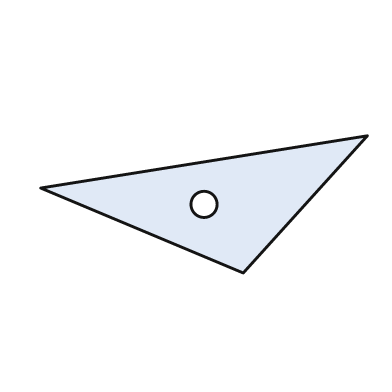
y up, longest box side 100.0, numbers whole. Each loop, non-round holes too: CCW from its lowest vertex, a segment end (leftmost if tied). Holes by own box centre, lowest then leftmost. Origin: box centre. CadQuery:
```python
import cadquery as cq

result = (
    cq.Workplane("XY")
    .moveTo(12.0, -21.0)
    .lineTo(50.0, 21.0)
    .lineTo(-50.0, 5.0)
    .close()
    .moveTo(0.0, 0.0)
    .circle(4.0)
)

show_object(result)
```